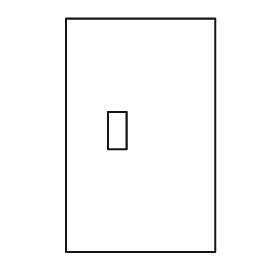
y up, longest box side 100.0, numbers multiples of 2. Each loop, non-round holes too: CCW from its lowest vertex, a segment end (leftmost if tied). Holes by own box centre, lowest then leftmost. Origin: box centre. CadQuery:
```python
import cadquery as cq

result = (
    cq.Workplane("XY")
    .moveTo(-32.0, -50.0)
    .lineTo(32.0, -50.0)
    .lineTo(32.0, 50.0)
    .lineTo(-32.0, 50.0)
    .close()
    .moveTo(-14.0, -6.0)
    .lineTo(-6.0, -6.0)
    .lineTo(-6.0, 10.0)
    .lineTo(-14.0, 10.0)
    .close()
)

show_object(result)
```